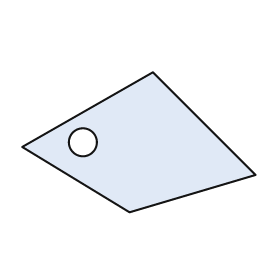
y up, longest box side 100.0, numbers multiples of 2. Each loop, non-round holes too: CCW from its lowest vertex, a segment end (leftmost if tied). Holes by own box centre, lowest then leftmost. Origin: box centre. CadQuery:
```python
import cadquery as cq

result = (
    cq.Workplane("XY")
    .moveTo(-4.0, -30.0)
    .lineTo(50.0, -14.0)
    .lineTo(6.0, 30.0)
    .lineTo(-50.0, -2.0)
    .close()
    .moveTo(-24.0, 0.0)
    .circle(6.0)
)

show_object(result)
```